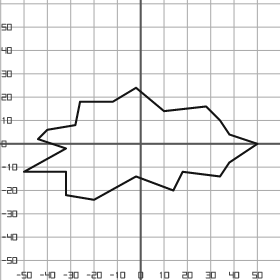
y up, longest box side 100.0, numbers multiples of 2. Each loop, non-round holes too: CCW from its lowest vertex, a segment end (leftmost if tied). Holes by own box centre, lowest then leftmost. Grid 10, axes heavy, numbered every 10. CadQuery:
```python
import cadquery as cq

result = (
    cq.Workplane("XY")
    .moveTo(-20.0, -24.0)
    .lineTo(-2.0, -14.0)
    .lineTo(14.0, -20.0)
    .lineTo(18.0, -12.0)
    .lineTo(34.0, -14.0)
    .lineTo(38.0, -8.0)
    .lineTo(50.0, 0.0)
    .lineTo(38.0, 4.0)
    .lineTo(34.0, 10.0)
    .lineTo(28.0, 16.0)
    .lineTo(10.0, 14.0)
    .lineTo(-2.0, 24.0)
    .lineTo(-12.0, 18.0)
    .lineTo(-26.0, 18.0)
    .lineTo(-28.0, 8.0)
    .lineTo(-40.0, 6.0)
    .lineTo(-44.0, 2.0)
    .lineTo(-32.0, -2.0)
    .lineTo(-50.0, -12.0)
    .lineTo(-32.0, -12.0)
    .lineTo(-32.0, -22.0)
    .close()
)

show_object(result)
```